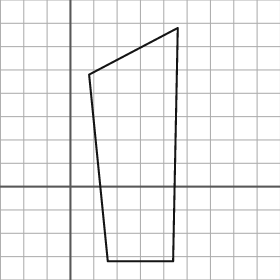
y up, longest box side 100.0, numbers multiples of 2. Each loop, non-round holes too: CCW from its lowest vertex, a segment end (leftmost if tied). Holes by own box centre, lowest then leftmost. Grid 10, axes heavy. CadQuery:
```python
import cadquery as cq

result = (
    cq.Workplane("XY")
    .moveTo(16.0, -32.0)
    .lineTo(44.0, -32.0)
    .lineTo(46.0, 68.0)
    .lineTo(8.0, 48.0)
    .close()
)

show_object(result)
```